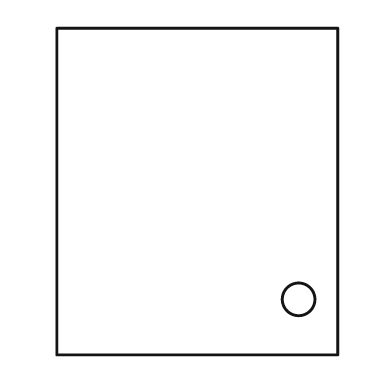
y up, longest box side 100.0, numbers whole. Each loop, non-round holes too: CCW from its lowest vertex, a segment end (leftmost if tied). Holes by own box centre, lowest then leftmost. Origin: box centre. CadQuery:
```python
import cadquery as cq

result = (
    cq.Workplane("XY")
    .moveTo(-43.0, -50.0)
    .lineTo(43.0, -50.0)
    .lineTo(43.0, 50.0)
    .lineTo(-43.0, 50.0)
    .close()
    .moveTo(31.0, -33.0)
    .circle(5.0)
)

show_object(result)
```